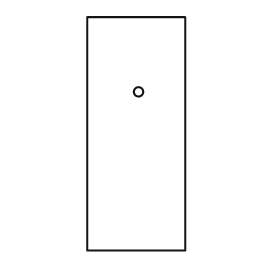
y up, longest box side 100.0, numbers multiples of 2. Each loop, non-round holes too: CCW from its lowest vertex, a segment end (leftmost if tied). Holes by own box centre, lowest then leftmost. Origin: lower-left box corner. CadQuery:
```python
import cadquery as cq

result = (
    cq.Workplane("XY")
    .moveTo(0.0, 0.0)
    .lineTo(42.0, 0.0)
    .lineTo(42.0, 100.0)
    .lineTo(0.0, 100.0)
    .close()
    .moveTo(22.0, 68.0)
    .circle(2.0)
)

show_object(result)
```